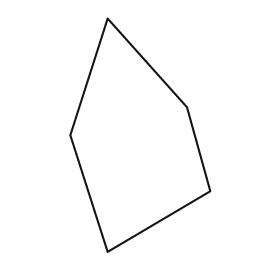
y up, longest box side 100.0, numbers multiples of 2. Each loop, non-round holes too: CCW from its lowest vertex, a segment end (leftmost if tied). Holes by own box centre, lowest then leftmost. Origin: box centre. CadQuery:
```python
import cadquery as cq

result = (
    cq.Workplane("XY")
    .moveTo(-14.0, -50.0)
    .lineTo(30.0, -24.0)
    .lineTo(20.0, 12.0)
    .lineTo(-14.0, 50.0)
    .lineTo(-30.0, 0.0)
    .close()
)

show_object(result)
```